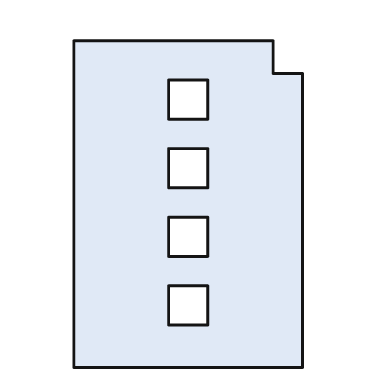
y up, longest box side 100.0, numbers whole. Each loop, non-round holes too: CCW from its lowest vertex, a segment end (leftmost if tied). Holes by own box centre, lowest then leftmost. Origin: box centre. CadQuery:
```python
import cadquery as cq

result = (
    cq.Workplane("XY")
    .moveTo(-35.0, -50.0)
    .lineTo(35.0, -50.0)
    .lineTo(35.0, 40.0)
    .lineTo(26.0, 40.0)
    .lineTo(26.0, 50.0)
    .lineTo(-35.0, 50.0)
    .close()
    .moveTo(-6.0, -37.0)
    .lineTo(6.0, -37.0)
    .lineTo(6.0, -25.0)
    .lineTo(-6.0, -25.0)
    .close()
    .moveTo(-6.0, -16.0)
    .lineTo(6.0, -16.0)
    .lineTo(6.0, -4.0)
    .lineTo(-6.0, -4.0)
    .close()
    .moveTo(-6.0, 5.0)
    .lineTo(6.0, 5.0)
    .lineTo(6.0, 17.0)
    .lineTo(-6.0, 17.0)
    .close()
    .moveTo(-6.0, 26.0)
    .lineTo(6.0, 26.0)
    .lineTo(6.0, 38.0)
    .lineTo(-6.0, 38.0)
    .close()
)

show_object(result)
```